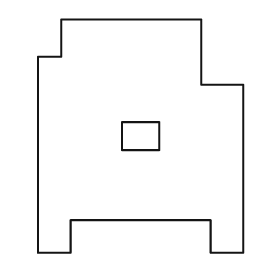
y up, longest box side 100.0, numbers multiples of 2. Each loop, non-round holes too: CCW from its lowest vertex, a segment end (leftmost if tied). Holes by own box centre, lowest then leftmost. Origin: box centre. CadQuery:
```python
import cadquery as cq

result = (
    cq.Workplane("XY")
    .moveTo(-44.0, -50.0)
    .lineTo(-30.0, -50.0)
    .lineTo(-30.0, -36.0)
    .lineTo(30.0, -36.0)
    .lineTo(30.0, -50.0)
    .lineTo(44.0, -50.0)
    .lineTo(44.0, 22.0)
    .lineTo(26.0, 22.0)
    .lineTo(26.0, 50.0)
    .lineTo(-34.0, 50.0)
    .lineTo(-34.0, 34.0)
    .lineTo(-44.0, 34.0)
    .close()
    .moveTo(-8.0, -6.0)
    .lineTo(8.0, -6.0)
    .lineTo(8.0, 6.0)
    .lineTo(-8.0, 6.0)
    .close()
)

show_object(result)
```